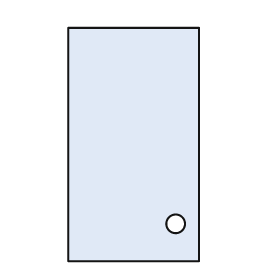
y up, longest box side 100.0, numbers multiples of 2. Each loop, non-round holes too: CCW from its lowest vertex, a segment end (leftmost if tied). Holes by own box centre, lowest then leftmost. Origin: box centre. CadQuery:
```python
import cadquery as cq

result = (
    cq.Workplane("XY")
    .moveTo(-28.0, -50.0)
    .lineTo(28.0, -50.0)
    .lineTo(28.0, 50.0)
    .lineTo(-28.0, 50.0)
    .close()
    .moveTo(18.0, -34.0)
    .circle(4.0)
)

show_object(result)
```